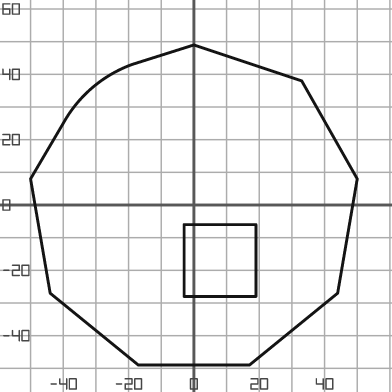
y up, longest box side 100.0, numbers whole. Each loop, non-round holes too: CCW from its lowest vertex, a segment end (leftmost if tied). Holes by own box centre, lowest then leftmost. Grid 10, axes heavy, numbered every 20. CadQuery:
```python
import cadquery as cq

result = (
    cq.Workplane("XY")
    .moveTo(-17.0, -49.0)
    .lineTo(17.0, -49.0)
    .lineTo(44.0, -27.0)
    .lineTo(50.0, 8.0)
    .lineTo(33.0, 38.0)
    .lineTo(0.0, 49.0)
    .lineTo(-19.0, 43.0)
    .threePointArc((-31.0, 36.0), (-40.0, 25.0))
    .lineTo(-50.0, 8.0)
    .lineTo(-44.0, -27.0)
    .close()
    .moveTo(-3.0, -28.0)
    .lineTo(19.0, -28.0)
    .lineTo(19.0, -6.0)
    .lineTo(-3.0, -6.0)
    .close()
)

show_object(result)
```